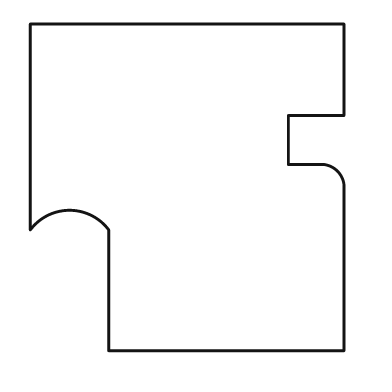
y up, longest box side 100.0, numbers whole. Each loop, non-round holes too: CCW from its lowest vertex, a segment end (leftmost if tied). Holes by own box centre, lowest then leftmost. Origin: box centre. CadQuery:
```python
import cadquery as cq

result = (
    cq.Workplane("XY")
    .moveTo(-24.0, -50.0)
    .lineTo(48.0, -50.0)
    .lineTo(48.0, 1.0)
    .threePointArc((46.0, 5.0), (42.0, 7.0))
    .lineTo(31.0, 7.0)
    .lineTo(31.0, 22.0)
    .lineTo(48.0, 22.0)
    .lineTo(48.0, 50.0)
    .lineTo(-48.0, 50.0)
    .lineTo(-48.0, -13.0)
    .threePointArc((-36.0, -7.0), (-24.0, -13.0))
    .close()
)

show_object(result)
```